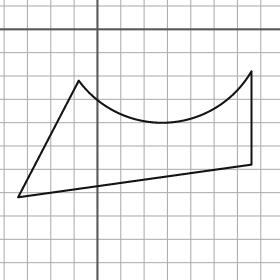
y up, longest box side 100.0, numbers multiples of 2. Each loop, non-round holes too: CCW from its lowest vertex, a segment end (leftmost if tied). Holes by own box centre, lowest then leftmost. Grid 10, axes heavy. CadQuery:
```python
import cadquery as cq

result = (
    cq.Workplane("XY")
    .moveTo(-34.0, -72.0)
    .lineTo(66.0, -58.0)
    .lineTo(66.0, -18.0)
    .threePointArc((30.0, -40.0), (-8.0, -22.0))
    .close()
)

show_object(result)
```